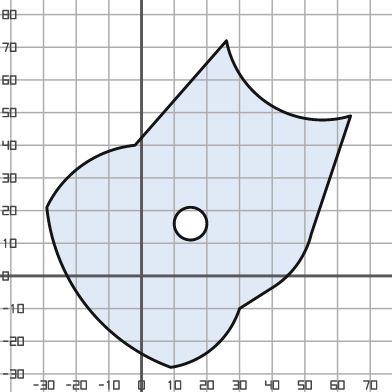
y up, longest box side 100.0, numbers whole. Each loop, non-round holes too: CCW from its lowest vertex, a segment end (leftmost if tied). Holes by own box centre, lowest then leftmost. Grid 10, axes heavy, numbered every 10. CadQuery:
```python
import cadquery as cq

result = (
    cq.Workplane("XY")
    .moveTo(9.0, -28.0)
    .threePointArc((22.0, -22.0), (30.0, -10.0))
    .lineTo(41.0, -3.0)
    .threePointArc((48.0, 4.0), (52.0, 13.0))
    .lineTo(64.0, 49.0)
    .threePointArc((40.0, 52.0), (26.0, 72.0))
    .lineTo(-2.0, 40.0)
    .threePointArc((-18.0, 34.0), (-29.0, 21.0))
    .threePointArc((-17.0, -9.0), (9.0, -28.0))
    .close()
    .moveTo(15.0, 16.0)
    .circle(5.0)
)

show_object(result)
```